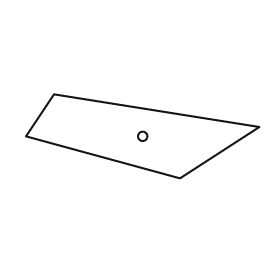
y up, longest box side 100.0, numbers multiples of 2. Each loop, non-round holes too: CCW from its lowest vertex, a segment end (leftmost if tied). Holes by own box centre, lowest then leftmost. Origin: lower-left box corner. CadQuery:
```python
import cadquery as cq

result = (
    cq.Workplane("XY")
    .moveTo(66.0, 0.0)
    .lineTo(100.0, 22.0)
    .lineTo(12.0, 36.0)
    .lineTo(0.0, 18.0)
    .close()
    .moveTo(50.0, 18.0)
    .circle(2.0)
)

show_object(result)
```